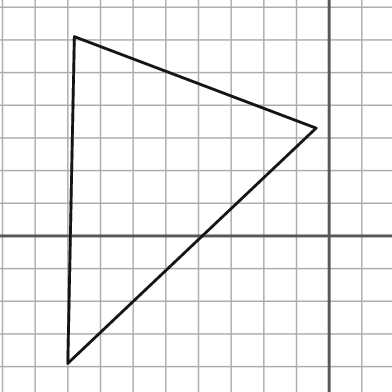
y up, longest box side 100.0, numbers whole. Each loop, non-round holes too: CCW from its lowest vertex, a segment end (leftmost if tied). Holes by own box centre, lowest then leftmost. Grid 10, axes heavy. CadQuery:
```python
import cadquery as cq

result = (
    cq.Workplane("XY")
    .moveTo(-80.0, -39.0)
    .lineTo(-4.0, 33.0)
    .lineTo(-78.0, 61.0)
    .close()
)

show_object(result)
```